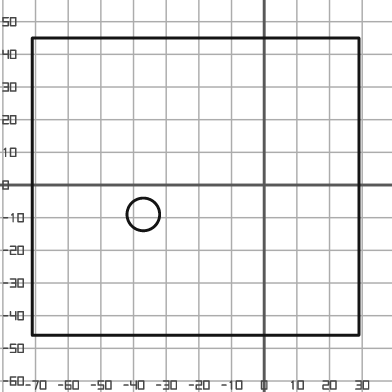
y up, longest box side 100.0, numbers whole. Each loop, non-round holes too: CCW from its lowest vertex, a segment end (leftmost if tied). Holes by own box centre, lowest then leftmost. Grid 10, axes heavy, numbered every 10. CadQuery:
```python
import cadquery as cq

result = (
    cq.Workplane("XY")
    .moveTo(-71.0, -46.0)
    .lineTo(29.0, -46.0)
    .lineTo(29.0, 45.0)
    .lineTo(-71.0, 45.0)
    .close()
    .moveTo(-37.0, -9.0)
    .circle(5.0)
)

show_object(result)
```